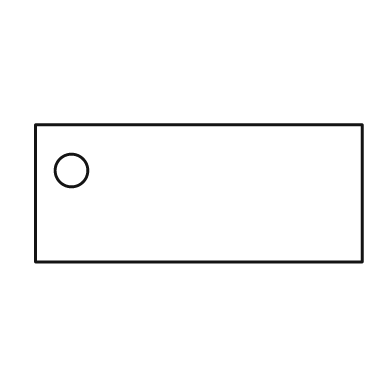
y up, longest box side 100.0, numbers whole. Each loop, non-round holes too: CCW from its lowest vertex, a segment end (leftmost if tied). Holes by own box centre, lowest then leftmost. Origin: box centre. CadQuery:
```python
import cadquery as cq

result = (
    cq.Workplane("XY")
    .moveTo(-50.0, -21.0)
    .lineTo(50.0, -21.0)
    .lineTo(50.0, 21.0)
    .lineTo(-50.0, 21.0)
    .close()
    .moveTo(-39.0, 7.0)
    .circle(5.0)
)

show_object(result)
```